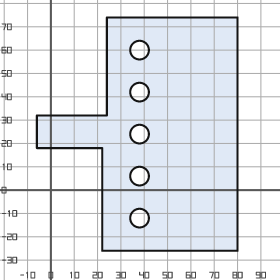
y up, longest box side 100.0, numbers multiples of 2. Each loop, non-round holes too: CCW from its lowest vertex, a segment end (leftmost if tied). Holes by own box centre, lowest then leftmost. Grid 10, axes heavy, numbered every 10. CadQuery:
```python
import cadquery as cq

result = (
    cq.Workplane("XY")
    .moveTo(22.0, -26.0)
    .lineTo(80.0, -26.0)
    .lineTo(80.0, 74.0)
    .lineTo(24.0, 74.0)
    .lineTo(24.0, 32.0)
    .lineTo(-6.0, 32.0)
    .lineTo(-6.0, 18.0)
    .lineTo(22.0, 18.0)
    .close()
    .moveTo(38.0, -12.0)
    .circle(4.0)
    .moveTo(38.0, 6.0)
    .circle(4.0)
    .moveTo(38.0, 24.0)
    .circle(4.0)
    .moveTo(38.0, 42.0)
    .circle(4.0)
    .moveTo(38.0, 60.0)
    .circle(4.0)
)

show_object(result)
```